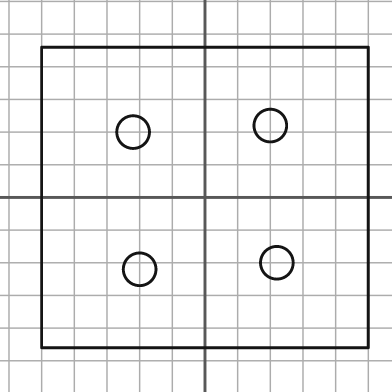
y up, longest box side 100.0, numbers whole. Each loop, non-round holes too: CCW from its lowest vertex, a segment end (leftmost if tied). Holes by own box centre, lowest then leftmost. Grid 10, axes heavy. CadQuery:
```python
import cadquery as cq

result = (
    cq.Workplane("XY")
    .moveTo(-50.0, -46.0)
    .lineTo(50.0, -46.0)
    .lineTo(50.0, 46.0)
    .lineTo(-50.0, 46.0)
    .close()
    .moveTo(-20.0, -22.0)
    .circle(5.0)
    .moveTo(22.0, -20.0)
    .circle(5.0)
    .moveTo(-22.0, 20.0)
    .circle(5.0)
    .moveTo(20.0, 22.0)
    .circle(5.0)
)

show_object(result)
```